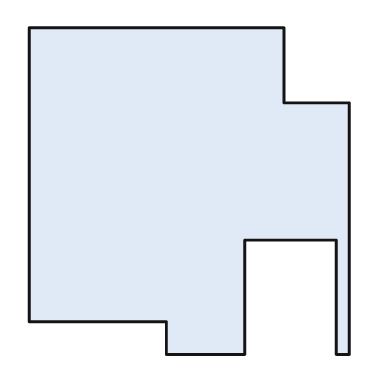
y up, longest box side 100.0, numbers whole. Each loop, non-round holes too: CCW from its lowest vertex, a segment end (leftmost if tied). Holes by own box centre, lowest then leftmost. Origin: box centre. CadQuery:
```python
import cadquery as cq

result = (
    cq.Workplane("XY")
    .moveTo(-7.0, -50.0)
    .lineTo(17.0, -50.0)
    .lineTo(17.0, -15.0)
    .lineTo(45.0, -15.0)
    .lineTo(45.0, -50.0)
    .lineTo(49.0, -50.0)
    .lineTo(49.0, 27.0)
    .lineTo(29.0, 27.0)
    .lineTo(29.0, 50.0)
    .lineTo(-49.0, 50.0)
    .lineTo(-49.0, -40.0)
    .lineTo(-7.0, -40.0)
    .close()
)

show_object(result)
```